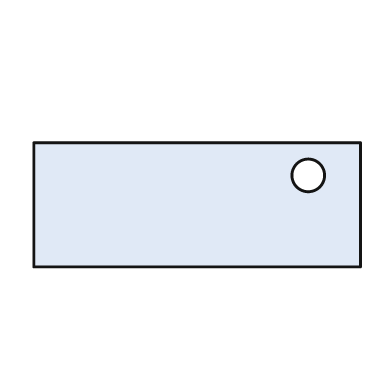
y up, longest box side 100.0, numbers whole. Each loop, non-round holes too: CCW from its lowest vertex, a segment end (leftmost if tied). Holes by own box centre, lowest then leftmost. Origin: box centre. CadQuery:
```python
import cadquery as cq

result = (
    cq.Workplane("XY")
    .moveTo(-50.0, -19.0)
    .lineTo(50.0, -19.0)
    .lineTo(50.0, 19.0)
    .lineTo(-50.0, 19.0)
    .close()
    .moveTo(34.0, 9.0)
    .circle(5.0)
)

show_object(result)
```